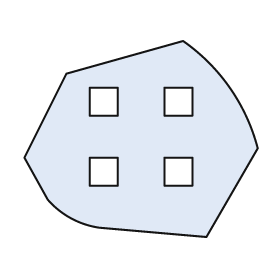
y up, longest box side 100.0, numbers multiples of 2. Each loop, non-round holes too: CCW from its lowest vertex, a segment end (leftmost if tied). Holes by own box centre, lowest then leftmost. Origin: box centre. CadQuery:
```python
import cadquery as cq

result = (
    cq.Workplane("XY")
    .moveTo(28.0, -42.0)
    .lineTo(50.0, -4.0)
    .threePointArc((38.0, 22.0), (18.0, 42.0))
    .lineTo(-32.0, 28.0)
    .lineTo(-50.0, -8.0)
    .lineTo(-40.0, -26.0)
    .threePointArc((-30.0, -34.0), (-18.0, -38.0))
    .close()
    .moveTo(-22.0, -20.0)
    .lineTo(-10.0, -20.0)
    .lineTo(-10.0, -8.0)
    .lineTo(-22.0, -8.0)
    .close()
    .moveTo(10.0, -20.0)
    .lineTo(22.0, -20.0)
    .lineTo(22.0, -8.0)
    .lineTo(10.0, -8.0)
    .close()
    .moveTo(-22.0, 10.0)
    .lineTo(-10.0, 10.0)
    .lineTo(-10.0, 22.0)
    .lineTo(-22.0, 22.0)
    .close()
    .moveTo(10.0, 10.0)
    .lineTo(22.0, 10.0)
    .lineTo(22.0, 22.0)
    .lineTo(10.0, 22.0)
    .close()
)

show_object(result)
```